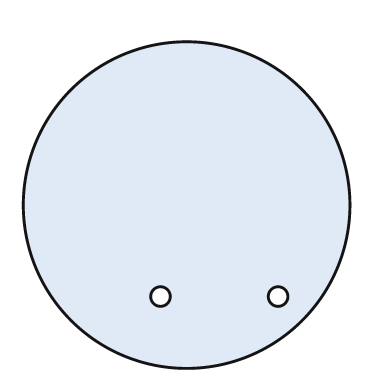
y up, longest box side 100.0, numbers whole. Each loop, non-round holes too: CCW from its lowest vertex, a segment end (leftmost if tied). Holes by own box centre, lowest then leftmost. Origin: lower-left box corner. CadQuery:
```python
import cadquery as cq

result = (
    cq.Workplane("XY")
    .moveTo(50.0, 50.0)
    .circle(50.0)
    .moveTo(42.0, 22.0)
    .circle(3.0)
    .moveTo(78.0, 22.0)
    .circle(3.0)
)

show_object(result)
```